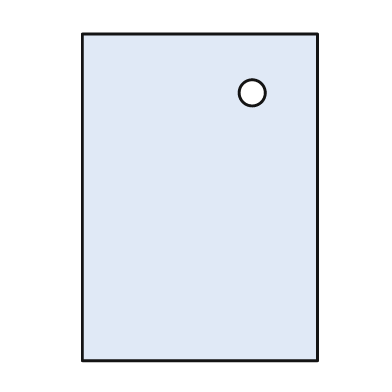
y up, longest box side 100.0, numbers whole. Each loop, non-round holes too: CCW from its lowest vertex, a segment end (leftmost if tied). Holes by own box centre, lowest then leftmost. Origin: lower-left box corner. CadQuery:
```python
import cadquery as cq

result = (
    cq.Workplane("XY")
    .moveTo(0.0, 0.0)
    .lineTo(72.0, 0.0)
    .lineTo(72.0, 100.0)
    .lineTo(0.0, 100.0)
    .close()
    .moveTo(52.0, 82.0)
    .circle(4.0)
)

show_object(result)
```